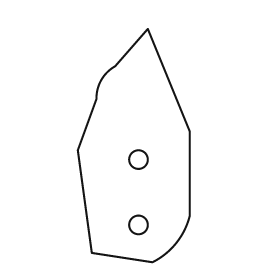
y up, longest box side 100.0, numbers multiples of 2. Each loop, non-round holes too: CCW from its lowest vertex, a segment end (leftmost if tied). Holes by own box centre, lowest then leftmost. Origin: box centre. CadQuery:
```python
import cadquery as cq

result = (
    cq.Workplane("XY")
    .moveTo(8.0, -50.0)
    .threePointArc((18.0, -42.0), (24.0, -30.0))
    .lineTo(24.0, 6.0)
    .lineTo(6.0, 50.0)
    .lineTo(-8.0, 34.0)
    .threePointArc((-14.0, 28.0), (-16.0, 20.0))
    .lineTo(-24.0, -2.0)
    .lineTo(-18.0, -46.0)
    .close()
    .moveTo(2.0, -34.0)
    .circle(4.0)
    .moveTo(2.0, -6.0)
    .circle(4.0)
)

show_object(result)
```